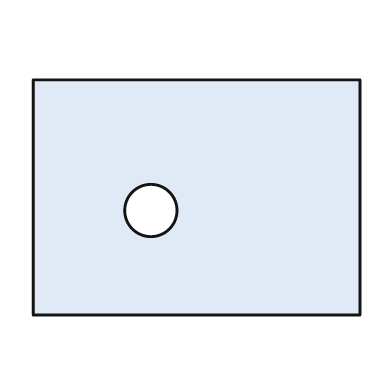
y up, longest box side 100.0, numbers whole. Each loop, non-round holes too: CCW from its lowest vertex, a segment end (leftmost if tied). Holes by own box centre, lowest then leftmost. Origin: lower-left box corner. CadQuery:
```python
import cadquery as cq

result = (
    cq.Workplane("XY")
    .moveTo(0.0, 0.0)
    .lineTo(100.0, 0.0)
    .lineTo(100.0, 72.0)
    .lineTo(0.0, 72.0)
    .close()
    .moveTo(36.0, 32.0)
    .circle(8.0)
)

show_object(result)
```